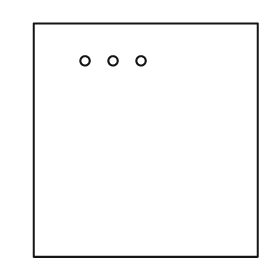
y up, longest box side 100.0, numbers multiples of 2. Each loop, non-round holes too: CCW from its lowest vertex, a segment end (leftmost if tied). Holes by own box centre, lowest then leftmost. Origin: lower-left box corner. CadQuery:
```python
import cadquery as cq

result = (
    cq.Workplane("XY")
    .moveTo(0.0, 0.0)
    .lineTo(96.0, 0.0)
    .lineTo(96.0, 100.0)
    .lineTo(0.0, 100.0)
    .close()
    .moveTo(22.0, 84.0)
    .circle(2.0)
    .moveTo(34.0, 84.0)
    .circle(2.0)
    .moveTo(46.0, 84.0)
    .circle(2.0)
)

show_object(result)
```